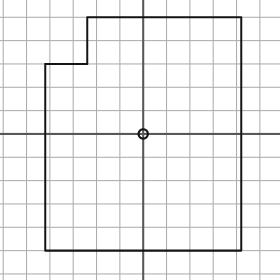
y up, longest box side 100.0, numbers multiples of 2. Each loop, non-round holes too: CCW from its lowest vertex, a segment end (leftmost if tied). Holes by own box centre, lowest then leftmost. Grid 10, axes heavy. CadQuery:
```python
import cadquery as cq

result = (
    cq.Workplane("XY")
    .moveTo(-42.0, -50.0)
    .lineTo(42.0, -50.0)
    .lineTo(42.0, 50.0)
    .lineTo(-24.0, 50.0)
    .lineTo(-24.0, 30.0)
    .lineTo(-42.0, 30.0)
    .close()
    .moveTo(0.0, 0.0)
    .circle(2.0)
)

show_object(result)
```